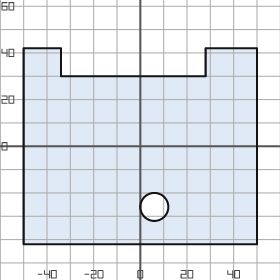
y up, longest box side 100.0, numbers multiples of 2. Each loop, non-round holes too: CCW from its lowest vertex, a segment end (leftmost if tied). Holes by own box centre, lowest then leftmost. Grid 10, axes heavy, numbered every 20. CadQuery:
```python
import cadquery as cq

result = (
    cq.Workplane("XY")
    .moveTo(-50.0, -42.0)
    .lineTo(50.0, -42.0)
    .lineTo(50.0, 42.0)
    .lineTo(28.0, 42.0)
    .lineTo(28.0, 30.0)
    .lineTo(-34.0, 30.0)
    .lineTo(-34.0, 42.0)
    .lineTo(-50.0, 42.0)
    .close()
    .moveTo(6.0, -26.0)
    .circle(6.0)
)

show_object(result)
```